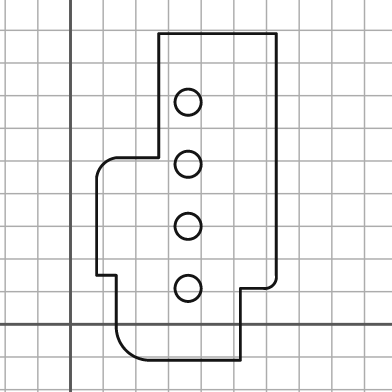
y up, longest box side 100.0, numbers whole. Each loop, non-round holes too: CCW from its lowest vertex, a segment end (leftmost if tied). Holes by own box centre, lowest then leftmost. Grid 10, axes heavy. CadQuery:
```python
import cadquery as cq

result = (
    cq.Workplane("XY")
    .moveTo(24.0, -11.0)
    .lineTo(52.0, -11.0)
    .lineTo(52.0, 11.0)
    .lineTo(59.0, 11.0)
    .threePointArc((62.0, 12.0), (63.0, 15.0))
    .lineTo(63.0, 89.0)
    .lineTo(27.0, 89.0)
    .lineTo(27.0, 51.0)
    .lineTo(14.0, 51.0)
    .threePointArc((10.0, 49.0), (8.0, 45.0))
    .lineTo(8.0, 15.0)
    .lineTo(14.0, 15.0)
    .lineTo(14.0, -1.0)
    .threePointArc((17.0, -8.0), (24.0, -11.0))
    .close()
    .moveTo(36.0, 11.0)
    .circle(4.0)
    .moveTo(36.0, 30.0)
    .circle(4.0)
    .moveTo(36.0, 49.0)
    .circle(4.0)
    .moveTo(36.0, 68.0)
    .circle(4.0)
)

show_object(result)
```